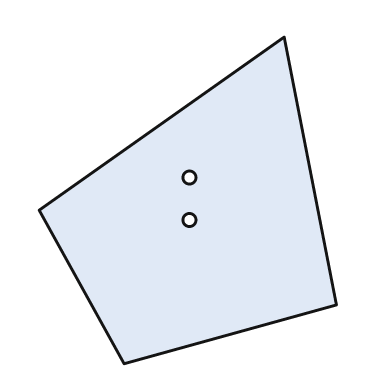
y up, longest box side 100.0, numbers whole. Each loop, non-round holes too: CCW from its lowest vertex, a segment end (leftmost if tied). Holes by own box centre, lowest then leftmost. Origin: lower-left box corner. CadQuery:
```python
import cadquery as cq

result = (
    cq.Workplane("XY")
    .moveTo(26.0, 0.0)
    .lineTo(91.0, 18.0)
    .lineTo(75.0, 100.0)
    .lineTo(0.0, 47.0)
    .close()
    .moveTo(46.0, 44.0)
    .circle(2.0)
    .moveTo(46.0, 57.0)
    .circle(2.0)
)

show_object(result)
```